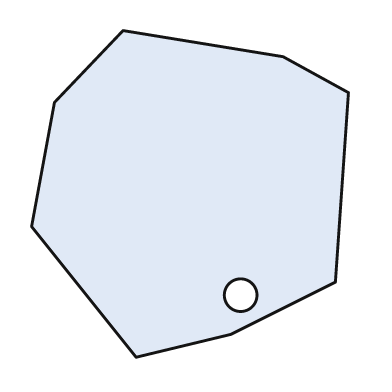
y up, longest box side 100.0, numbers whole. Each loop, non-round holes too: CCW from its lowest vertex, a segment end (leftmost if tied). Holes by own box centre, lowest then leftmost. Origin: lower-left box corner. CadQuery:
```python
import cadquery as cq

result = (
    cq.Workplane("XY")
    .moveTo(32.0, 0.0)
    .lineTo(61.0, 7.0)
    .lineTo(93.0, 23.0)
    .lineTo(97.0, 81.0)
    .lineTo(77.0, 92.0)
    .lineTo(28.0, 100.0)
    .lineTo(7.0, 78.0)
    .lineTo(0.0, 40.0)
    .close()
    .moveTo(64.0, 19.0)
    .circle(5.0)
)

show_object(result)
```